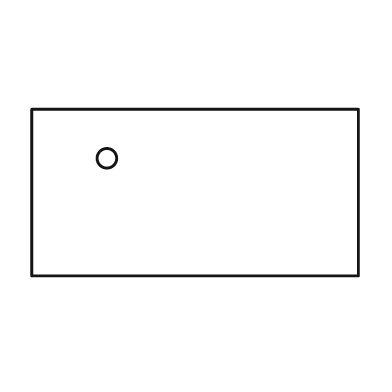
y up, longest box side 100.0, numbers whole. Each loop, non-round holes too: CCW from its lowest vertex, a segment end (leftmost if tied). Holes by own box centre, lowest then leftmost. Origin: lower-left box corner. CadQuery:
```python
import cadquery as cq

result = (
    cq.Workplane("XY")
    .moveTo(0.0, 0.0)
    .lineTo(100.0, 0.0)
    .lineTo(100.0, 51.0)
    .lineTo(0.0, 51.0)
    .close()
    .moveTo(23.0, 36.0)
    .circle(3.0)
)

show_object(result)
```